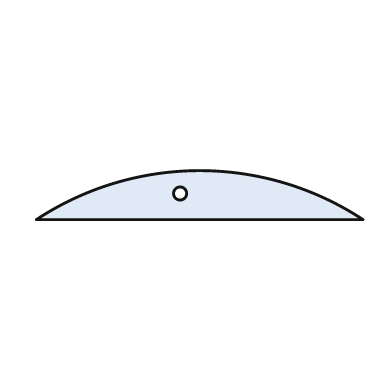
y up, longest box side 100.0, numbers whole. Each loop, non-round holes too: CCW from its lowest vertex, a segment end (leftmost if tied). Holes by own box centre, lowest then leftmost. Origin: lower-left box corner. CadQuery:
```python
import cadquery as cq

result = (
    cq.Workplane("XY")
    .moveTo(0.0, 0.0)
    .lineTo(100.0, 0.0)
    .threePointArc((50.0, 15.0), (0.0, 0.0))
    .close()
    .moveTo(44.0, 8.0)
    .circle(2.0)
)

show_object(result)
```